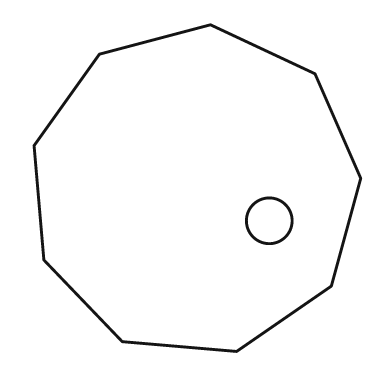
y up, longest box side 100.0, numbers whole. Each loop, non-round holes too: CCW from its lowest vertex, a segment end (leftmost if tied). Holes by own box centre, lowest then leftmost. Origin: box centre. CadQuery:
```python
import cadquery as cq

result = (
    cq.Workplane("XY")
    .moveTo(12.0, -50.0)
    .lineTo(41.0, -30.0)
    .lineTo(50.0, 3.0)
    .lineTo(36.0, 35.0)
    .lineTo(4.0, 50.0)
    .lineTo(-30.0, 41.0)
    .lineTo(-50.0, 13.0)
    .lineTo(-47.0, -22.0)
    .lineTo(-23.0, -47.0)
    .close()
    .moveTo(22.0, -10.0)
    .circle(7.0)
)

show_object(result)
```